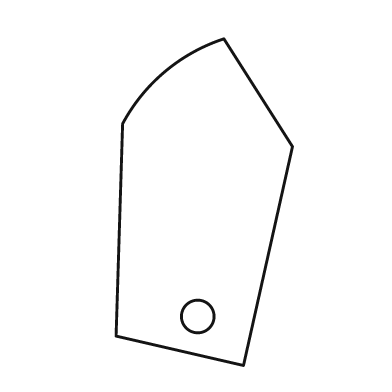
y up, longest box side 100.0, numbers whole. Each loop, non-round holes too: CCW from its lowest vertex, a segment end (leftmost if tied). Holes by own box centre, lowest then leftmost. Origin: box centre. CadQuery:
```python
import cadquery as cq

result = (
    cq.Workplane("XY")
    .moveTo(12.0, -50.0)
    .lineTo(27.0, 17.0)
    .lineTo(6.0, 50.0)
    .threePointArc((-12.0, 40.0), (-25.0, 24.0))
    .lineTo(-27.0, -41.0)
    .close()
    .moveTo(-2.0, -35.0)
    .circle(5.0)
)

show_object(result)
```